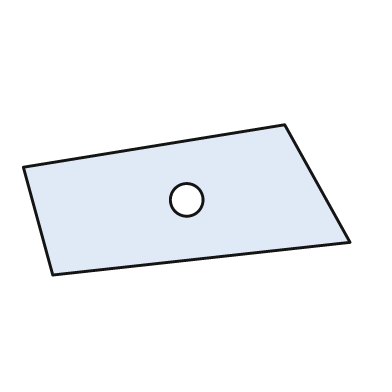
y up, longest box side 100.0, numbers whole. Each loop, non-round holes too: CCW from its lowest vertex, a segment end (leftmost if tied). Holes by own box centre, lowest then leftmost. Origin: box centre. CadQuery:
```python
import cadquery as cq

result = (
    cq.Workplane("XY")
    .moveTo(-41.0, -23.0)
    .lineTo(50.0, -13.0)
    .lineTo(30.0, 23.0)
    .lineTo(-50.0, 10.0)
    .close()
    .moveTo(0.0, 0.0)
    .circle(5.0)
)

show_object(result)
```